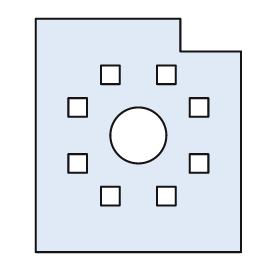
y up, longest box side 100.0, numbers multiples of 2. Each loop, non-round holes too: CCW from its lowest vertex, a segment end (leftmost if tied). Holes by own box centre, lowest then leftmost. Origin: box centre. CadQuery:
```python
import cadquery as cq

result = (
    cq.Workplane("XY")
    .moveTo(-44.0, -50.0)
    .lineTo(44.0, -50.0)
    .lineTo(44.0, 36.0)
    .lineTo(18.0, 36.0)
    .lineTo(18.0, 50.0)
    .lineTo(-44.0, 50.0)
    .close()
    .moveTo(-16.0, -30.0)
    .lineTo(-8.0, -30.0)
    .lineTo(-8.0, -22.0)
    .lineTo(-16.0, -22.0)
    .close()
    .moveTo(8.0, -30.0)
    .lineTo(16.0, -30.0)
    .lineTo(16.0, -22.0)
    .lineTo(8.0, -22.0)
    .close()
    .moveTo(-30.0, -16.0)
    .lineTo(-22.0, -16.0)
    .lineTo(-22.0, -8.0)
    .lineTo(-30.0, -8.0)
    .close()
    .moveTo(22.0, -16.0)
    .lineTo(30.0, -16.0)
    .lineTo(30.0, -8.0)
    .lineTo(22.0, -8.0)
    .close()
    .moveTo(0.0, 0.0)
    .circle(12.0)
    .moveTo(-30.0, 8.0)
    .lineTo(-22.0, 8.0)
    .lineTo(-22.0, 16.0)
    .lineTo(-30.0, 16.0)
    .close()
    .moveTo(22.0, 8.0)
    .lineTo(30.0, 8.0)
    .lineTo(30.0, 16.0)
    .lineTo(22.0, 16.0)
    .close()
    .moveTo(-16.0, 22.0)
    .lineTo(-8.0, 22.0)
    .lineTo(-8.0, 30.0)
    .lineTo(-16.0, 30.0)
    .close()
    .moveTo(8.0, 22.0)
    .lineTo(16.0, 22.0)
    .lineTo(16.0, 30.0)
    .lineTo(8.0, 30.0)
    .close()
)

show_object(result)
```